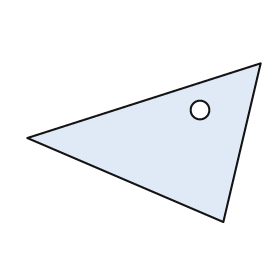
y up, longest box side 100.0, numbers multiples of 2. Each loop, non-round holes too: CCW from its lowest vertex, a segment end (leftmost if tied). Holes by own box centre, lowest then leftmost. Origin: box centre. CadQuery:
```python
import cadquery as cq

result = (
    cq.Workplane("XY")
    .moveTo(34.0, -34.0)
    .lineTo(50.0, 34.0)
    .lineTo(-50.0, 2.0)
    .close()
    .moveTo(24.0, 14.0)
    .circle(4.0)
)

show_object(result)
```